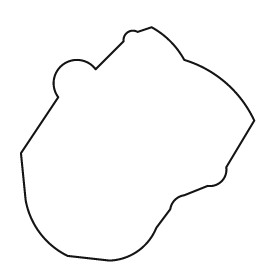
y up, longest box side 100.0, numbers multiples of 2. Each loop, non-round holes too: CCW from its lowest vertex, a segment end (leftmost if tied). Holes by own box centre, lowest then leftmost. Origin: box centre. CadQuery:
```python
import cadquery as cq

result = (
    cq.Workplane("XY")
    .moveTo(-12.0, -50.0)
    .threePointArc((0.0, -46.0), (8.0, -36.0))
    .lineTo(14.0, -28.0)
    .threePointArc((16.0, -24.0), (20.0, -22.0))
    .lineTo(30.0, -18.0)
    .threePointArc((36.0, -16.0), (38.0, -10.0))
    .lineTo(50.0, 10.0)
    .threePointArc((38.0, 26.0), (20.0, 36.0))
    .threePointArc((14.0, 44.0), (6.0, 50.0))
    .lineTo(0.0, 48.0)
    .threePointArc((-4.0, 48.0), (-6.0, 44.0))
    .lineTo(-18.0, 32.0)
    .threePointArc((-32.0, 34.0), (-34.0, 20.0))
    .lineTo(-50.0, -4.0)
    .lineTo(-48.0, -24.0)
    .threePointArc((-42.0, -38.0), (-30.0, -48.0))
    .close()
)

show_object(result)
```